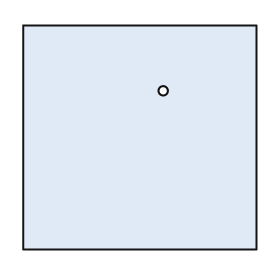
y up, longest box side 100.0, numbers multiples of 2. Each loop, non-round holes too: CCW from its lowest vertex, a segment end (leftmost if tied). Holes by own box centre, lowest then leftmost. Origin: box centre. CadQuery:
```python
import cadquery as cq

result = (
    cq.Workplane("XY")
    .moveTo(-50.0, -48.0)
    .lineTo(50.0, -48.0)
    .lineTo(50.0, 48.0)
    .lineTo(-50.0, 48.0)
    .close()
    .moveTo(10.0, 20.0)
    .circle(2.0)
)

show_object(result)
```